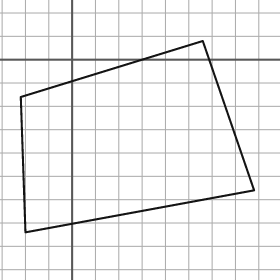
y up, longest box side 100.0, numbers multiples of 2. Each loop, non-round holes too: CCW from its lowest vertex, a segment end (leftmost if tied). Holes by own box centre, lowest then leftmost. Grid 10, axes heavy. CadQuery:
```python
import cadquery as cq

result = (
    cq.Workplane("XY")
    .moveTo(-20.0, -74.0)
    .lineTo(78.0, -56.0)
    .lineTo(56.0, 8.0)
    .lineTo(-22.0, -16.0)
    .close()
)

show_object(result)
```